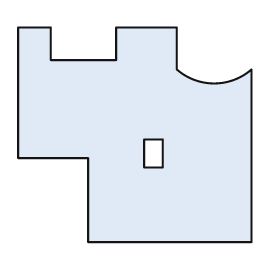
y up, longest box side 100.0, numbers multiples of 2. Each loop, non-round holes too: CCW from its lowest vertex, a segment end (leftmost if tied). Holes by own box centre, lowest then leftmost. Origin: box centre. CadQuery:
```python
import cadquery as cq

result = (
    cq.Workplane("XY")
    .moveTo(-20.0, -46.0)
    .lineTo(50.0, -46.0)
    .lineTo(50.0, 28.0)
    .threePointArc((34.0, 22.0), (18.0, 28.0))
    .lineTo(18.0, 46.0)
    .lineTo(-8.0, 46.0)
    .lineTo(-8.0, 32.0)
    .lineTo(-36.0, 32.0)
    .lineTo(-36.0, 46.0)
    .lineTo(-50.0, 46.0)
    .lineTo(-50.0, -10.0)
    .lineTo(-20.0, -10.0)
    .close()
    .moveTo(4.0, -14.0)
    .lineTo(12.0, -14.0)
    .lineTo(12.0, -2.0)
    .lineTo(4.0, -2.0)
    .close()
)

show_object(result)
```